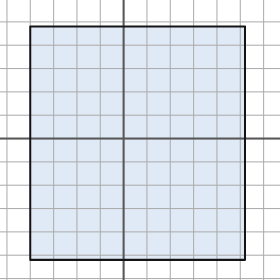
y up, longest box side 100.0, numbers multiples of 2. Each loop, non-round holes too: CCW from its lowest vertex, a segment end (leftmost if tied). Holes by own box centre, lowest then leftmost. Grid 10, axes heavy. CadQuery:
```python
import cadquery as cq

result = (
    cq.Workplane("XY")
    .moveTo(-40.0, -52.0)
    .lineTo(52.0, -52.0)
    .lineTo(52.0, 48.0)
    .lineTo(-40.0, 48.0)
    .close()
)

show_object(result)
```